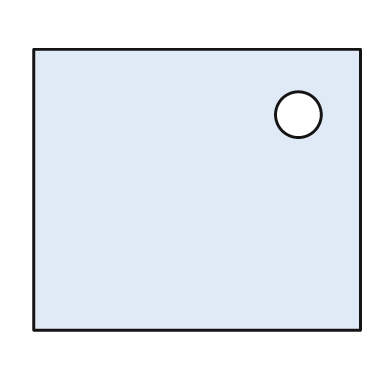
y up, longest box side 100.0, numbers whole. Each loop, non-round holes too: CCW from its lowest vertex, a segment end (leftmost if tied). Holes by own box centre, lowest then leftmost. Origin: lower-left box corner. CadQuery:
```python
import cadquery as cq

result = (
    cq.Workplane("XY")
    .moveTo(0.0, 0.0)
    .lineTo(100.0, 0.0)
    .lineTo(100.0, 86.0)
    .lineTo(0.0, 86.0)
    .close()
    .moveTo(81.0, 66.0)
    .circle(7.0)
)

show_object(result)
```